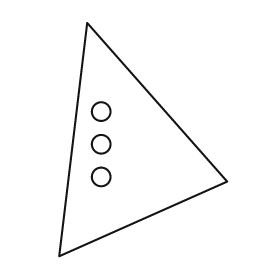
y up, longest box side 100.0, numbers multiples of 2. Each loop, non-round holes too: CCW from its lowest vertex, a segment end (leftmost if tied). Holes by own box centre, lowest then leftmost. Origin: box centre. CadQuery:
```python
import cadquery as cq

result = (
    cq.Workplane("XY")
    .moveTo(-36.0, -50.0)
    .lineTo(36.0, -18.0)
    .lineTo(-24.0, 50.0)
    .close()
    .moveTo(-18.0, -16.0)
    .circle(4.0)
    .moveTo(-18.0, -2.0)
    .circle(4.0)
    .moveTo(-18.0, 12.0)
    .circle(4.0)
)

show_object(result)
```